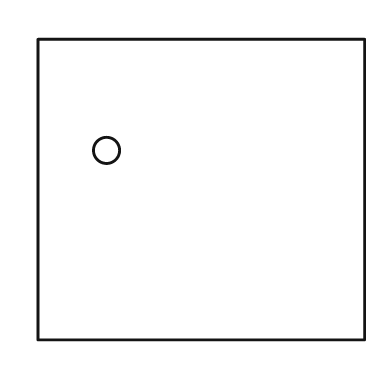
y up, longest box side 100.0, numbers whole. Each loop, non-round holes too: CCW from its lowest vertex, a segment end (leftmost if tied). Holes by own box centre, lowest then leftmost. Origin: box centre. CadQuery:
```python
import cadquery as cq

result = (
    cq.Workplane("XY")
    .moveTo(-50.0, -46.0)
    .lineTo(50.0, -46.0)
    .lineTo(50.0, 46.0)
    .lineTo(-50.0, 46.0)
    .close()
    .moveTo(-29.0, 12.0)
    .circle(4.0)
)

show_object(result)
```